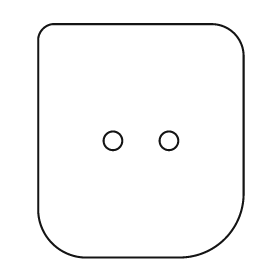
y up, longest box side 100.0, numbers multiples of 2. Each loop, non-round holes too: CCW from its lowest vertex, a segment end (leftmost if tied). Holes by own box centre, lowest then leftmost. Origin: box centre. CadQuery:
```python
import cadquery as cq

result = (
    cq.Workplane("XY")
    .moveTo(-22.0, -50.0)
    .lineTo(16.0, -50.0)
    .threePointArc((36.0, -42.0), (44.0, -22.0))
    .lineTo(44.0, 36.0)
    .threePointArc((40.0, 46.0), (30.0, 50.0))
    .lineTo(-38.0, 50.0)
    .threePointArc((-42.0, 48.0), (-44.0, 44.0))
    .lineTo(-44.0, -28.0)
    .threePointArc((-38.0, -44.0), (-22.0, -50.0))
    .close()
    .moveTo(-12.0, 0.0)
    .circle(4.0)
    .moveTo(12.0, 0.0)
    .circle(4.0)
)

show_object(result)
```